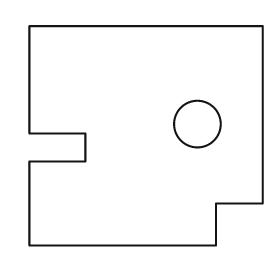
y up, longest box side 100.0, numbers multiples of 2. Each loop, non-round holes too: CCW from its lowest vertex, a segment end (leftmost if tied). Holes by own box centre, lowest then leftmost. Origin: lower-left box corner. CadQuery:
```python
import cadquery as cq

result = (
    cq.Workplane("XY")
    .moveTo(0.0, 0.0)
    .lineTo(80.0, 0.0)
    .lineTo(80.0, 18.0)
    .lineTo(100.0, 18.0)
    .lineTo(100.0, 94.0)
    .lineTo(0.0, 94.0)
    .lineTo(0.0, 48.0)
    .lineTo(24.0, 48.0)
    .lineTo(24.0, 36.0)
    .lineTo(0.0, 36.0)
    .close()
    .moveTo(72.0, 52.0)
    .circle(10.0)
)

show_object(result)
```